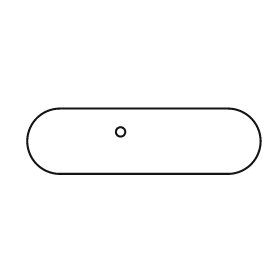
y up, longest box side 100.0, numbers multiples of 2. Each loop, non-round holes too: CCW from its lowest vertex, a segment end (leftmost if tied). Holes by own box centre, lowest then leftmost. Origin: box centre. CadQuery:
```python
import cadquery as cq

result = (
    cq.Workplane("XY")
    .moveTo(-36.0, -14.0)
    .lineTo(36.0, -14.0)
    .threePointArc((50.0, 0.0), (36.0, 14.0))
    .lineTo(-36.0, 14.0)
    .threePointArc((-50.0, 0.0), (-36.0, -14.0))
    .close()
    .moveTo(-10.0, 4.0)
    .circle(2.0)
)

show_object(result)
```